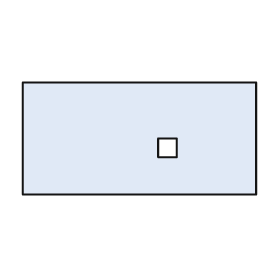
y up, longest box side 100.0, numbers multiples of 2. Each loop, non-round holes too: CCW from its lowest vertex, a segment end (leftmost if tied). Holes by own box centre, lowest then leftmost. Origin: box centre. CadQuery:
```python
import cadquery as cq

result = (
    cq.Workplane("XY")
    .moveTo(-50.0, -24.0)
    .lineTo(50.0, -24.0)
    .lineTo(50.0, 24.0)
    .lineTo(-50.0, 24.0)
    .close()
    .moveTo(8.0, -8.0)
    .lineTo(16.0, -8.0)
    .lineTo(16.0, 0.0)
    .lineTo(8.0, 0.0)
    .close()
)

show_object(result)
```